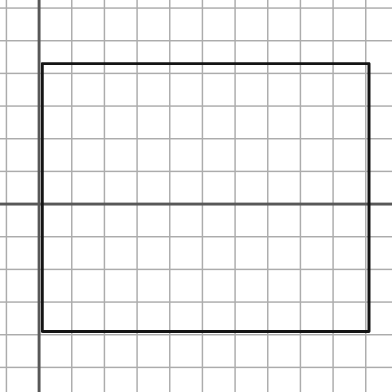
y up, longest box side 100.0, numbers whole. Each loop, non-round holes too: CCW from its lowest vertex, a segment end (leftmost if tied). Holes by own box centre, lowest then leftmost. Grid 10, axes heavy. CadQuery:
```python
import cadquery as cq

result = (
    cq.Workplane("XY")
    .moveTo(1.0, -39.0)
    .lineTo(101.0, -39.0)
    .lineTo(101.0, 43.0)
    .lineTo(1.0, 43.0)
    .close()
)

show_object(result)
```